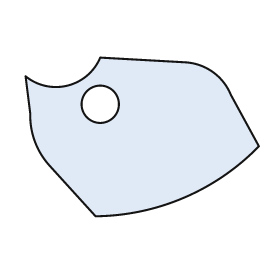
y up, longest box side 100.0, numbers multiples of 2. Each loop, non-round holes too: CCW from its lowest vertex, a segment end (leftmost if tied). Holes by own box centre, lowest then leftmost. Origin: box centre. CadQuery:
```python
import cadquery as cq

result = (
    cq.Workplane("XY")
    .moveTo(-20.0, -34.0)
    .threePointArc((18.0, -26.0), (50.0, -4.0))
    .lineTo(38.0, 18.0)
    .threePointArc((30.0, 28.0), (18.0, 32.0))
    .lineTo(-18.0, 34.0)
    .threePointArc((-32.0, 22.0), (-50.0, 26.0))
    .lineTo(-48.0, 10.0)
    .threePointArc((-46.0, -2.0), (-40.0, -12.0))
    .close()
    .moveTo(-18.0, 14.0)
    .circle(8.0)
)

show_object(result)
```